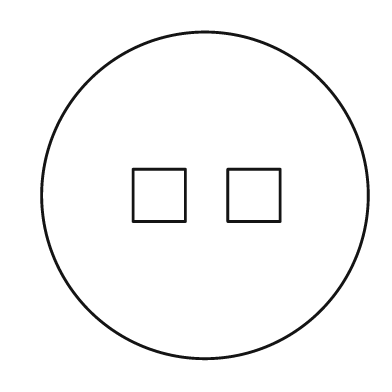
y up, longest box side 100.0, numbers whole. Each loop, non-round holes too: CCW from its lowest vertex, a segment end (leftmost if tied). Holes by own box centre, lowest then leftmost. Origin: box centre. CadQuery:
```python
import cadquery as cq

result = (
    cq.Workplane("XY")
    .moveTo(0.0, 0.0)
    .circle(50.0)
    .moveTo(-22.0, -8.0)
    .lineTo(-6.0, -8.0)
    .lineTo(-6.0, 8.0)
    .lineTo(-22.0, 8.0)
    .close()
    .moveTo(7.0, -8.0)
    .lineTo(23.0, -8.0)
    .lineTo(23.0, 8.0)
    .lineTo(7.0, 8.0)
    .close()
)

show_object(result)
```